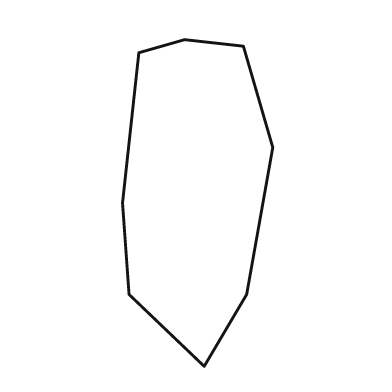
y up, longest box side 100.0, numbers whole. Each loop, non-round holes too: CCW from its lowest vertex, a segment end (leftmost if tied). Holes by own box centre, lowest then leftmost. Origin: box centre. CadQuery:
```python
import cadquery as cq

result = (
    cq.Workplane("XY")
    .moveTo(2.0, -50.0)
    .lineTo(15.0, -28.0)
    .lineTo(23.0, 17.0)
    .lineTo(14.0, 48.0)
    .lineTo(-4.0, 50.0)
    .lineTo(-18.0, 46.0)
    .lineTo(-23.0, 0.0)
    .lineTo(-21.0, -28.0)
    .close()
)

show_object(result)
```